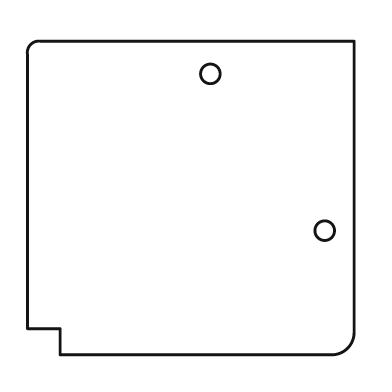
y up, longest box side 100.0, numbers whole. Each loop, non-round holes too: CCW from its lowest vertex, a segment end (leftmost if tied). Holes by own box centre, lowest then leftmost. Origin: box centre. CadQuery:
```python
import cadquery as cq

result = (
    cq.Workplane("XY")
    .moveTo(-40.0, -48.0)
    .lineTo(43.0, -48.0)
    .threePointArc((48.0, -46.0), (50.0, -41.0))
    .lineTo(50.0, 48.0)
    .lineTo(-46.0, 48.0)
    .threePointArc((-49.0, 47.0), (-50.0, 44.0))
    .lineTo(-50.0, -40.0)
    .lineTo(-40.0, -40.0)
    .close()
    .moveTo(41.0, -10.0)
    .circle(3.0)
    .moveTo(6.0, 38.0)
    .circle(3.0)
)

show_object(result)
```